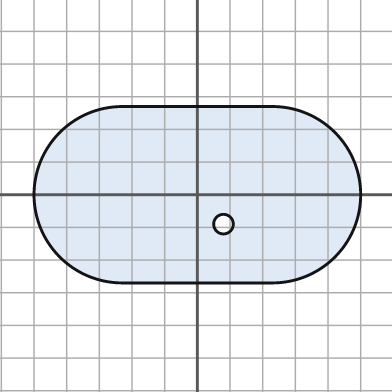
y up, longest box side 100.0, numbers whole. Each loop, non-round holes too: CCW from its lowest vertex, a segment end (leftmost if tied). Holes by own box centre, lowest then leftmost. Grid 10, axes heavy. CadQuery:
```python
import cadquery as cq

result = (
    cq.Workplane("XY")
    .moveTo(-23.0, -27.0)
    .lineTo(23.0, -27.0)
    .threePointArc((50.0, 0.0), (23.0, 27.0))
    .lineTo(-23.0, 27.0)
    .threePointArc((-50.0, 0.0), (-23.0, -27.0))
    .close()
    .moveTo(8.0, -9.0)
    .circle(3.0)
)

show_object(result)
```